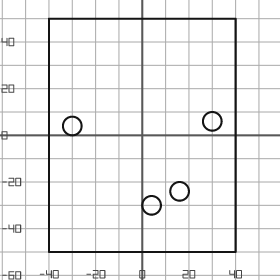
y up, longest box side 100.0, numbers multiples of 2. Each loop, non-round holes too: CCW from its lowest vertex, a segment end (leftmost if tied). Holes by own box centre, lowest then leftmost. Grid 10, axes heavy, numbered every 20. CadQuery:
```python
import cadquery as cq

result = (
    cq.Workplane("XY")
    .moveTo(-40.0, -50.0)
    .lineTo(40.0, -50.0)
    .lineTo(40.0, 50.0)
    .lineTo(-40.0, 50.0)
    .close()
    .moveTo(4.0, -30.0)
    .circle(4.0)
    .moveTo(16.0, -24.0)
    .circle(4.0)
    .moveTo(-30.0, 4.0)
    .circle(4.0)
    .moveTo(30.0, 6.0)
    .circle(4.0)
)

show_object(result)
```